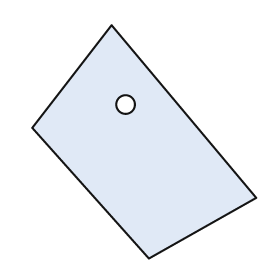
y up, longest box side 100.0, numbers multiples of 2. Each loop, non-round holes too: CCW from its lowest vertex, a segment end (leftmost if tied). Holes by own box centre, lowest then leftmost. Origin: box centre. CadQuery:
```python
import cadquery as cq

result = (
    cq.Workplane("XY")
    .moveTo(2.0, -50.0)
    .lineTo(48.0, -24.0)
    .lineTo(-14.0, 50.0)
    .lineTo(-48.0, 6.0)
    .close()
    .moveTo(-8.0, 16.0)
    .circle(4.0)
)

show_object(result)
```